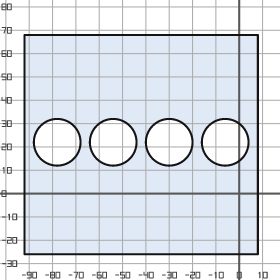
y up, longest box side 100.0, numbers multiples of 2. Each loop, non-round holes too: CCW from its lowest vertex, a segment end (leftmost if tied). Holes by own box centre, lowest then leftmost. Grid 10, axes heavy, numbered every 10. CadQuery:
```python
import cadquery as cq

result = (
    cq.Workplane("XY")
    .moveTo(-92.0, -26.0)
    .lineTo(8.0, -26.0)
    .lineTo(8.0, 68.0)
    .lineTo(-92.0, 68.0)
    .close()
    .moveTo(-78.0, 22.0)
    .circle(10.0)
    .moveTo(-54.0, 22.0)
    .circle(10.0)
    .moveTo(-30.0, 22.0)
    .circle(10.0)
    .moveTo(-6.0, 22.0)
    .circle(10.0)
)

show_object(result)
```